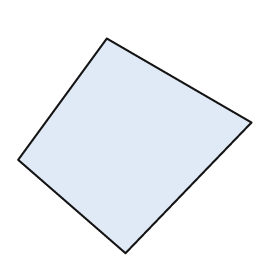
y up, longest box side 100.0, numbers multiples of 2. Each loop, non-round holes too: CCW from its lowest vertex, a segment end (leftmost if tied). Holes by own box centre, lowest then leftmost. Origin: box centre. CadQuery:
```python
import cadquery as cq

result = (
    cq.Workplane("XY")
    .moveTo(-4.0, -46.0)
    .lineTo(50.0, 10.0)
    .lineTo(-12.0, 46.0)
    .lineTo(-50.0, -6.0)
    .close()
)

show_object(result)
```